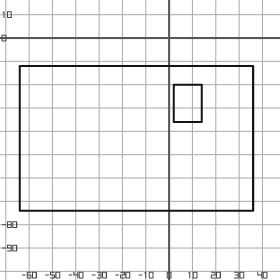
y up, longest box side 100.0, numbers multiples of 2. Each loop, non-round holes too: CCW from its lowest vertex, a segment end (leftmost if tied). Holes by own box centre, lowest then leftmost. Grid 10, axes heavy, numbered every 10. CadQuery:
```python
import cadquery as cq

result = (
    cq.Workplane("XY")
    .moveTo(-64.0, -74.0)
    .lineTo(36.0, -74.0)
    .lineTo(36.0, -12.0)
    .lineTo(-64.0, -12.0)
    .close()
    .moveTo(2.0, -36.0)
    .lineTo(14.0, -36.0)
    .lineTo(14.0, -20.0)
    .lineTo(2.0, -20.0)
    .close()
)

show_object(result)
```